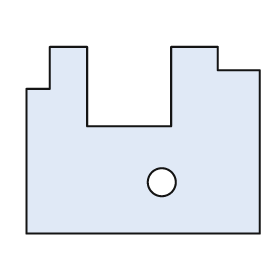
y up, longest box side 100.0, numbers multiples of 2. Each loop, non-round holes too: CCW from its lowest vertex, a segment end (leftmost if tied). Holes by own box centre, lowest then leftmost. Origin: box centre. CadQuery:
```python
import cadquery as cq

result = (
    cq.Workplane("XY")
    .moveTo(-50.0, -40.0)
    .lineTo(50.0, -40.0)
    .lineTo(50.0, 30.0)
    .lineTo(32.0, 30.0)
    .lineTo(32.0, 40.0)
    .lineTo(12.0, 40.0)
    .lineTo(12.0, 6.0)
    .lineTo(-24.0, 6.0)
    .lineTo(-24.0, 40.0)
    .lineTo(-40.0, 40.0)
    .lineTo(-40.0, 22.0)
    .lineTo(-50.0, 22.0)
    .close()
    .moveTo(8.0, -18.0)
    .circle(6.0)
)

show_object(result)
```